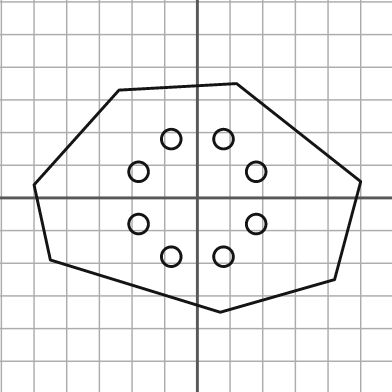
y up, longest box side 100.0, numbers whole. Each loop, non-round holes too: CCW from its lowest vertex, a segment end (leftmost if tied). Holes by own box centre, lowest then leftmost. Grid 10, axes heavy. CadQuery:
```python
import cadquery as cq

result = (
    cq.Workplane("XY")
    .moveTo(7.0, -35.0)
    .lineTo(42.0, -25.0)
    .lineTo(50.0, 5.0)
    .lineTo(12.0, 35.0)
    .lineTo(-24.0, 33.0)
    .lineTo(-50.0, 4.0)
    .lineTo(-45.0, -19.0)
    .close()
    .moveTo(-8.0, -18.0)
    .circle(3.0)
    .moveTo(8.0, -18.0)
    .circle(3.0)
    .moveTo(-18.0, -8.0)
    .circle(3.0)
    .moveTo(18.0, -8.0)
    .circle(3.0)
    .moveTo(-18.0, 8.0)
    .circle(3.0)
    .moveTo(18.0, 8.0)
    .circle(3.0)
    .moveTo(-8.0, 18.0)
    .circle(3.0)
    .moveTo(8.0, 18.0)
    .circle(3.0)
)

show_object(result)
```